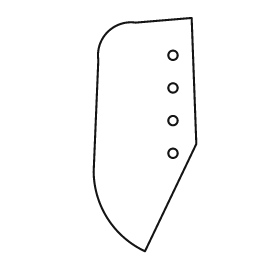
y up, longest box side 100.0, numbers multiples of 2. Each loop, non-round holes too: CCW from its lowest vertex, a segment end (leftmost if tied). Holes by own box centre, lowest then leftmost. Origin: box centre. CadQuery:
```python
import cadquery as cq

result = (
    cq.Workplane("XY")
    .moveTo(0.0, -50.0)
    .lineTo(22.0, -4.0)
    .lineTo(20.0, 50.0)
    .lineTo(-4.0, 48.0)
    .threePointArc((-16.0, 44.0), (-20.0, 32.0))
    .lineTo(-22.0, -16.0)
    .threePointArc((-16.0, -36.0), (0.0, -50.0))
    .close()
    .moveTo(12.0, -8.0)
    .circle(2.0)
    .moveTo(12.0, 6.0)
    .circle(2.0)
    .moveTo(12.0, 20.0)
    .circle(2.0)
    .moveTo(12.0, 34.0)
    .circle(2.0)
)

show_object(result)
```